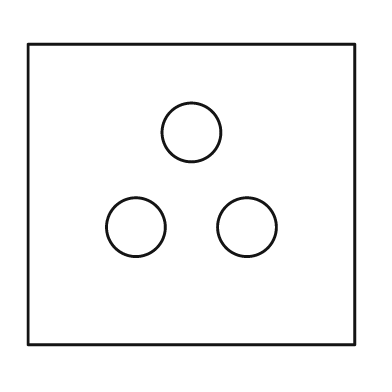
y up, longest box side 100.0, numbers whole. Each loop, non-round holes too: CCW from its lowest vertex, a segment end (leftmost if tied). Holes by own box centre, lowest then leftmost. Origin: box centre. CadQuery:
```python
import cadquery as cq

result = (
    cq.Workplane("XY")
    .moveTo(-50.0, -46.0)
    .lineTo(50.0, -46.0)
    .lineTo(50.0, 46.0)
    .lineTo(-50.0, 46.0)
    .close()
    .moveTo(-17.0, -10.0)
    .circle(9.0)
    .moveTo(17.0, -10.0)
    .circle(9.0)
    .moveTo(0.0, 19.0)
    .circle(9.0)
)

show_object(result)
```